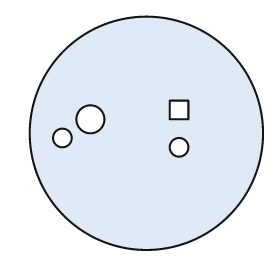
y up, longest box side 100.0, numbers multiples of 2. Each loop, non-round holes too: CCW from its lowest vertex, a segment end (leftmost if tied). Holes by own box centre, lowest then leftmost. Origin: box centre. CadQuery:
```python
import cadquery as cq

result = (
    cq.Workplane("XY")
    .moveTo(0.0, 0.0)
    .circle(50.0)
    .moveTo(14.0, -6.0)
    .circle(4.0)
    .moveTo(-36.0, -2.0)
    .circle(4.0)
    .moveTo(-24.0, 6.0)
    .circle(6.0)
    .moveTo(10.0, 6.0)
    .lineTo(18.0, 6.0)
    .lineTo(18.0, 14.0)
    .lineTo(10.0, 14.0)
    .close()
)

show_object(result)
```